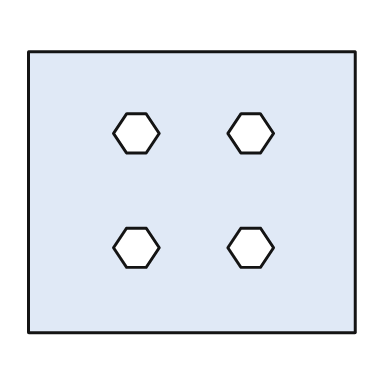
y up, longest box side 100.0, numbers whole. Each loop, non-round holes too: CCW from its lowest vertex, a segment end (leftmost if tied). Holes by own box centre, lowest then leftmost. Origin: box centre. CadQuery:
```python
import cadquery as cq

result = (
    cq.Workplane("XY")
    .moveTo(-50.0, -43.0)
    .lineTo(50.0, -43.0)
    .lineTo(50.0, 43.0)
    .lineTo(-50.0, 43.0)
    .close()
    .moveTo(-20.0, -23.0)
    .lineTo(-14.0, -23.0)
    .lineTo(-10.0, -17.0)
    .lineTo(-14.0, -11.0)
    .lineTo(-20.0, -11.0)
    .lineTo(-24.0, -17.0)
    .close()
    .moveTo(15.0, -23.0)
    .lineTo(21.0, -23.0)
    .lineTo(25.0, -17.0)
    .lineTo(21.0, -11.0)
    .lineTo(15.0, -11.0)
    .lineTo(11.0, -17.0)
    .close()
    .moveTo(-20.0, 12.0)
    .lineTo(-14.0, 12.0)
    .lineTo(-10.0, 18.0)
    .lineTo(-14.0, 24.0)
    .lineTo(-20.0, 24.0)
    .lineTo(-24.0, 18.0)
    .close()
    .moveTo(15.0, 12.0)
    .lineTo(21.0, 12.0)
    .lineTo(25.0, 18.0)
    .lineTo(21.0, 24.0)
    .lineTo(15.0, 24.0)
    .lineTo(11.0, 18.0)
    .close()
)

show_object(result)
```